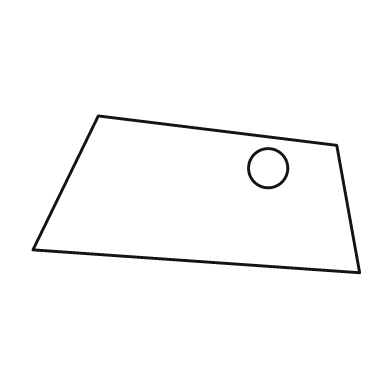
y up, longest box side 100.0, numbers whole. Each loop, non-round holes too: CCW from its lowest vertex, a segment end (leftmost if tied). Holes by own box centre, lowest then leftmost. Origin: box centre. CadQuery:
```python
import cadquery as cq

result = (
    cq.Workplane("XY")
    .moveTo(50.0, -24.0)
    .lineTo(43.0, 15.0)
    .lineTo(-30.0, 24.0)
    .lineTo(-50.0, -17.0)
    .close()
    .moveTo(22.0, 8.0)
    .circle(6.0)
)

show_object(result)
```